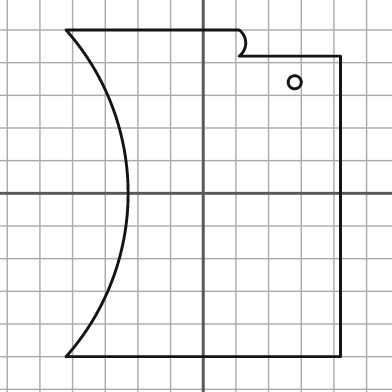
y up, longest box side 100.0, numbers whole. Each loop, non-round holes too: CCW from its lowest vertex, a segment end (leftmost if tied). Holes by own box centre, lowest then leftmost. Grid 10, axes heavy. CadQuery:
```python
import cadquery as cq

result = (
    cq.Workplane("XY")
    .moveTo(-42.0, -50.0)
    .lineTo(42.0, -50.0)
    .lineTo(42.0, 42.0)
    .lineTo(11.0, 42.0)
    .threePointArc((13.0, 46.0), (11.0, 50.0))
    .lineTo(-42.0, 50.0)
    .threePointArc((-23.0, 0.0), (-42.0, -50.0))
    .close()
    .moveTo(28.0, 34.0)
    .circle(2.0)
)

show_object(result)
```